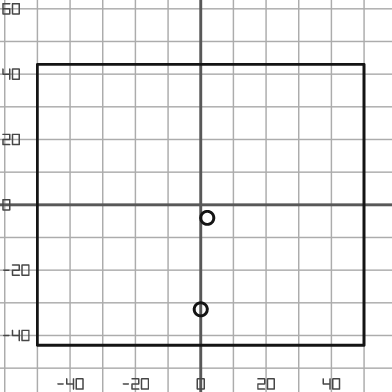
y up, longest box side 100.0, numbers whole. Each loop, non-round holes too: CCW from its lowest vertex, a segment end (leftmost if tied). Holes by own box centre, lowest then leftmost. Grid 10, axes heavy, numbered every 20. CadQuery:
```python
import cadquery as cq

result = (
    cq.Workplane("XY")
    .moveTo(-50.0, -43.0)
    .lineTo(50.0, -43.0)
    .lineTo(50.0, 43.0)
    .lineTo(-50.0, 43.0)
    .close()
    .moveTo(0.0, -32.0)
    .circle(2.0)
    .moveTo(2.0, -4.0)
    .circle(2.0)
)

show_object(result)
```